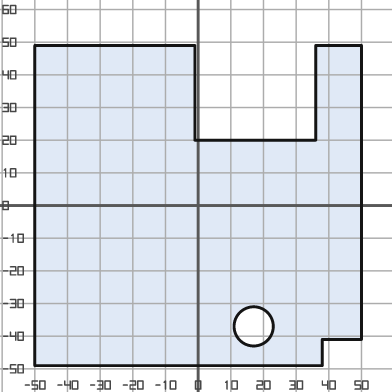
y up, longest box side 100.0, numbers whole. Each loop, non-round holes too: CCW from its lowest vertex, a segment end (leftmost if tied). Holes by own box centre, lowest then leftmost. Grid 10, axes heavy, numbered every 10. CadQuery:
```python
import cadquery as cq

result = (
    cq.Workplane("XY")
    .moveTo(-50.0, -49.0)
    .lineTo(38.0, -49.0)
    .lineTo(38.0, -41.0)
    .lineTo(50.0, -41.0)
    .lineTo(50.0, 49.0)
    .lineTo(36.0, 49.0)
    .lineTo(36.0, 20.0)
    .lineTo(-1.0, 20.0)
    .lineTo(-1.0, 49.0)
    .lineTo(-50.0, 49.0)
    .close()
    .moveTo(17.0, -37.0)
    .circle(6.0)
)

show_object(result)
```